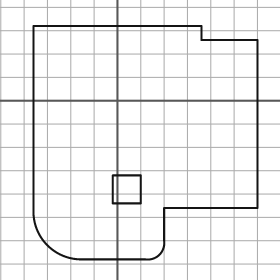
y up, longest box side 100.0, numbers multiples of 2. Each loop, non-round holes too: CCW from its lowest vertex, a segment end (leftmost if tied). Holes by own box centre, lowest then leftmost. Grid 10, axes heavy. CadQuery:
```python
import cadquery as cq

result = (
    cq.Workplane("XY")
    .moveTo(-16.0, -68.0)
    .lineTo(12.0, -68.0)
    .threePointArc((18.0, -66.0), (20.0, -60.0))
    .lineTo(20.0, -46.0)
    .lineTo(60.0, -46.0)
    .lineTo(60.0, 26.0)
    .lineTo(36.0, 26.0)
    .lineTo(36.0, 32.0)
    .lineTo(-36.0, 32.0)
    .lineTo(-36.0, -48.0)
    .threePointArc((-30.0, -62.0), (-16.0, -68.0))
    .close()
    .moveTo(-2.0, -44.0)
    .lineTo(10.0, -44.0)
    .lineTo(10.0, -32.0)
    .lineTo(-2.0, -32.0)
    .close()
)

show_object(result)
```